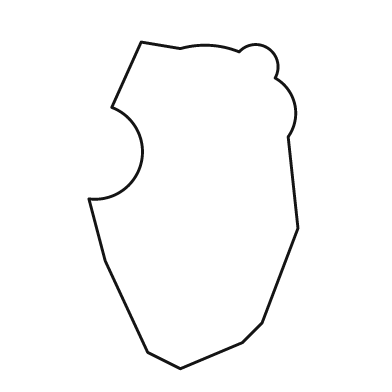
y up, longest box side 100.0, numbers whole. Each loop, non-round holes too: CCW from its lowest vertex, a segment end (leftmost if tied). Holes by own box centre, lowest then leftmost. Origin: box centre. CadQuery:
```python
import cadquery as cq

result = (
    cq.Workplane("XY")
    .moveTo(-4.0, -50.0)
    .lineTo(15.0, -42.0)
    .lineTo(21.0, -36.0)
    .lineTo(32.0, -7.0)
    .lineTo(29.0, 21.0)
    .threePointArc((31.0, 31.0), (25.0, 39.0))
    .threePointArc((23.0, 48.0), (14.0, 47.0))
    .threePointArc((5.0, 49.0), (-4.0, 48.0))
    .lineTo(-16.0, 50.0)
    .lineTo(-25.0, 30.0)
    .threePointArc((-16.0, 13.0), (-32.0, 2.0))
    .lineTo(-27.0, -17.0)
    .lineTo(-14.0, -45.0)
    .close()
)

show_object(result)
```